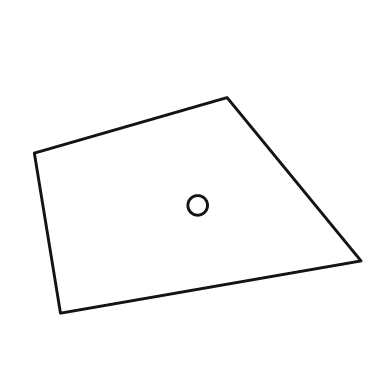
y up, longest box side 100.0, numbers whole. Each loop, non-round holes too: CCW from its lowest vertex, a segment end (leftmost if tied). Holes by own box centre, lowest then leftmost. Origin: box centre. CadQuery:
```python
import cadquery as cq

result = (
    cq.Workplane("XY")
    .moveTo(-42.0, -33.0)
    .lineTo(50.0, -17.0)
    .lineTo(9.0, 33.0)
    .lineTo(-50.0, 16.0)
    .close()
    .moveTo(0.0, 0.0)
    .circle(3.0)
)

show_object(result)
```